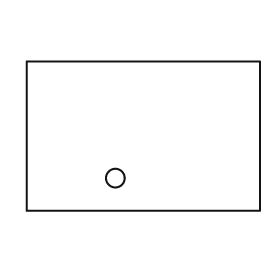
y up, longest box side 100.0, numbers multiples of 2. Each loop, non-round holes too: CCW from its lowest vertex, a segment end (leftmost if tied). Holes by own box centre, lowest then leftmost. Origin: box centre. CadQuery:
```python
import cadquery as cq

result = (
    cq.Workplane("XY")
    .moveTo(-50.0, -32.0)
    .lineTo(50.0, -32.0)
    .lineTo(50.0, 32.0)
    .lineTo(-50.0, 32.0)
    .close()
    .moveTo(-12.0, -18.0)
    .circle(4.0)
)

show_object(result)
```